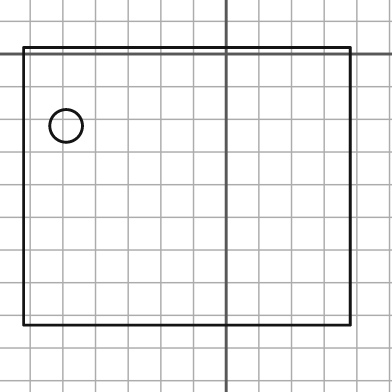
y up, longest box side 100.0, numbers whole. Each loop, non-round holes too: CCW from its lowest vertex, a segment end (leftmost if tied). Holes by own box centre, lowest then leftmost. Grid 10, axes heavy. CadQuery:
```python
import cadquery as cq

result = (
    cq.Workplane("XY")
    .moveTo(-62.0, -83.0)
    .lineTo(38.0, -83.0)
    .lineTo(38.0, 2.0)
    .lineTo(-62.0, 2.0)
    .close()
    .moveTo(-49.0, -22.0)
    .circle(5.0)
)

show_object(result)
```